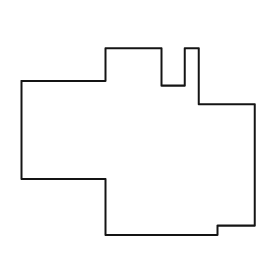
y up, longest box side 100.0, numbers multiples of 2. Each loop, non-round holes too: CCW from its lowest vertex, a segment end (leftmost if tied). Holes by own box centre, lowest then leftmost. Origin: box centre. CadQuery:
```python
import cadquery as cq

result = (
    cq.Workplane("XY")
    .moveTo(-14.0, -40.0)
    .lineTo(34.0, -40.0)
    .lineTo(34.0, -36.0)
    .lineTo(50.0, -36.0)
    .lineTo(50.0, 16.0)
    .lineTo(26.0, 16.0)
    .lineTo(26.0, 40.0)
    .lineTo(20.0, 40.0)
    .lineTo(20.0, 24.0)
    .lineTo(10.0, 24.0)
    .lineTo(10.0, 40.0)
    .lineTo(-14.0, 40.0)
    .lineTo(-14.0, 26.0)
    .lineTo(-50.0, 26.0)
    .lineTo(-50.0, -16.0)
    .lineTo(-14.0, -16.0)
    .close()
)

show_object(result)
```